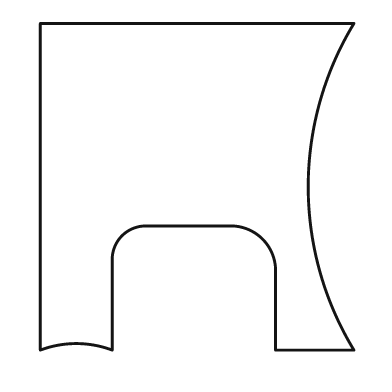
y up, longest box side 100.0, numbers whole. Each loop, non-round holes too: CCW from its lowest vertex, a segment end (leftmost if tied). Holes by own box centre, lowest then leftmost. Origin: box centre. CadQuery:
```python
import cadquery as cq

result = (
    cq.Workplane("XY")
    .moveTo(-48.0, -50.0)
    .threePointArc((-37.0, -48.0), (-26.0, -50.0))
    .lineTo(-26.0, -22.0)
    .threePointArc((-23.0, -15.0), (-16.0, -12.0))
    .lineTo(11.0, -12.0)
    .threePointArc((20.0, -16.0), (24.0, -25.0))
    .lineTo(24.0, -50.0)
    .lineTo(48.0, -50.0)
    .threePointArc((34.0, 0.0), (48.0, 50.0))
    .lineTo(-48.0, 50.0)
    .close()
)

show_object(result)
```